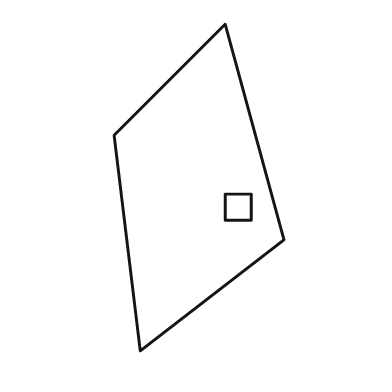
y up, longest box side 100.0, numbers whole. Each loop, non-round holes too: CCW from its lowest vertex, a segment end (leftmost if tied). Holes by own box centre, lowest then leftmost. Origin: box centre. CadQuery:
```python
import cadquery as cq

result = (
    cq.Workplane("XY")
    .moveTo(-18.0, -50.0)
    .lineTo(26.0, -16.0)
    .lineTo(8.0, 50.0)
    .lineTo(-26.0, 16.0)
    .close()
    .moveTo(8.0, -10.0)
    .lineTo(16.0, -10.0)
    .lineTo(16.0, -2.0)
    .lineTo(8.0, -2.0)
    .close()
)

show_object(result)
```